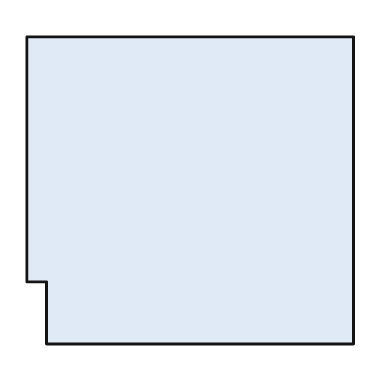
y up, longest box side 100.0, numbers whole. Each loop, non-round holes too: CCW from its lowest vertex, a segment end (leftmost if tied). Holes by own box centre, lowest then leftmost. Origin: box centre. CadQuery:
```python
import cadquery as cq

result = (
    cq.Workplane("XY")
    .moveTo(-44.0, -47.0)
    .lineTo(50.0, -47.0)
    .lineTo(50.0, 47.0)
    .lineTo(-50.0, 47.0)
    .lineTo(-50.0, -28.0)
    .lineTo(-44.0, -28.0)
    .close()
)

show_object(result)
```